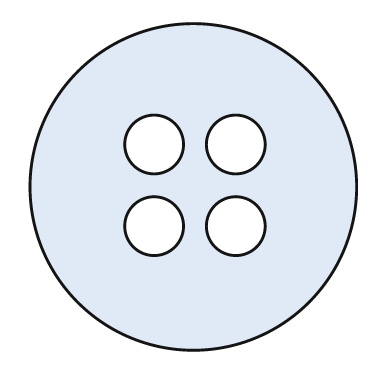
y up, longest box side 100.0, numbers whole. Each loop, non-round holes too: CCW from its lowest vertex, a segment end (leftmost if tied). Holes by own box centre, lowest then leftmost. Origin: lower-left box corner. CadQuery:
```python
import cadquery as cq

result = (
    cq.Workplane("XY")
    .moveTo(50.0, 50.0)
    .circle(50.0)
    .moveTo(38.0, 38.0)
    .circle(9.0)
    .moveTo(63.0, 38.0)
    .circle(9.0)
    .moveTo(38.0, 63.0)
    .circle(9.0)
    .moveTo(63.0, 63.0)
    .circle(9.0)
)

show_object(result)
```